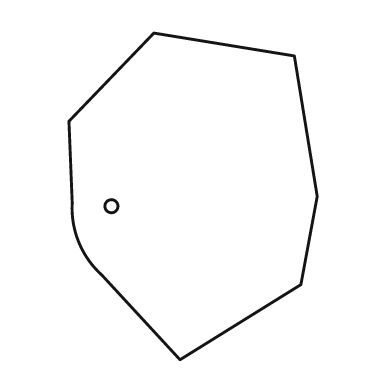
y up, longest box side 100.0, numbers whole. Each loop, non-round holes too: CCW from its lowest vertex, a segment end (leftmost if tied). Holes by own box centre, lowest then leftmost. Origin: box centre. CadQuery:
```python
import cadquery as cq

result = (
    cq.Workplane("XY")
    .moveTo(-4.0, -50.0)
    .lineTo(33.0, -27.0)
    .lineTo(38.0, 0.0)
    .lineTo(31.0, 43.0)
    .lineTo(-12.0, 50.0)
    .lineTo(-38.0, 23.0)
    .lineTo(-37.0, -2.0)
    .threePointArc((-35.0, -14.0), (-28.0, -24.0))
    .close()
    .moveTo(-25.0, -3.0)
    .circle(2.0)
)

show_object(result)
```